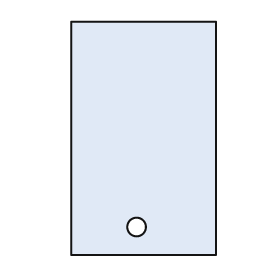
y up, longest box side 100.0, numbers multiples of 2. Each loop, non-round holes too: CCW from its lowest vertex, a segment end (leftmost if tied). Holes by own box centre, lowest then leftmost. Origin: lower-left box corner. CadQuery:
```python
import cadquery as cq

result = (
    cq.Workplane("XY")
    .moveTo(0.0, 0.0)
    .lineTo(62.0, 0.0)
    .lineTo(62.0, 100.0)
    .lineTo(0.0, 100.0)
    .close()
    .moveTo(28.0, 12.0)
    .circle(4.0)
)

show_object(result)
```